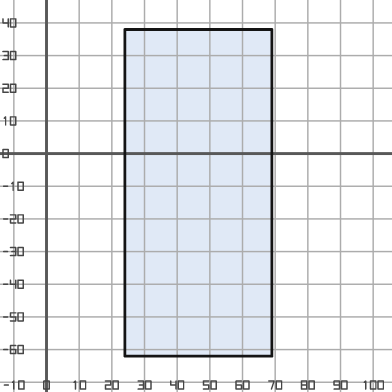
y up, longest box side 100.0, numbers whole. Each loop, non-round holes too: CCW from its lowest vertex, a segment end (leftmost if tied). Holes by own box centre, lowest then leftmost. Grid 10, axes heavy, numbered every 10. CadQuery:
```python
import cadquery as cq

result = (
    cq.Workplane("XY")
    .moveTo(24.0, -62.0)
    .lineTo(69.0, -62.0)
    .lineTo(69.0, 38.0)
    .lineTo(24.0, 38.0)
    .close()
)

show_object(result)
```